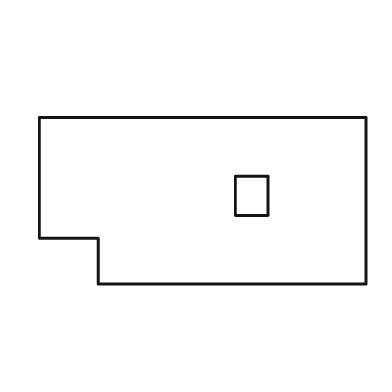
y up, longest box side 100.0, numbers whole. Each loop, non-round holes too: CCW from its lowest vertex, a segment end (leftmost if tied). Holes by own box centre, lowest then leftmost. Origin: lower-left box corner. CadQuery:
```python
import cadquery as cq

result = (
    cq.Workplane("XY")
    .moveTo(18.0, 0.0)
    .lineTo(100.0, 0.0)
    .lineTo(100.0, 51.0)
    .lineTo(0.0, 51.0)
    .lineTo(0.0, 14.0)
    .lineTo(18.0, 14.0)
    .close()
    .moveTo(60.0, 21.0)
    .lineTo(70.0, 21.0)
    .lineTo(70.0, 33.0)
    .lineTo(60.0, 33.0)
    .close()
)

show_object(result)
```